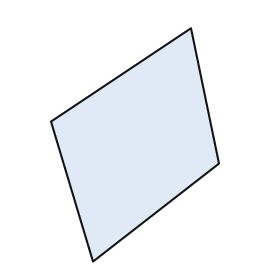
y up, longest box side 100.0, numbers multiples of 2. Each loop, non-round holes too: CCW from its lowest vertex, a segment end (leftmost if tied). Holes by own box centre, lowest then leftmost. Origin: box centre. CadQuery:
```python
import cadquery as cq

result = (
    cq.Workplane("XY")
    .moveTo(-18.0, -50.0)
    .lineTo(36.0, -8.0)
    .lineTo(24.0, 50.0)
    .lineTo(-36.0, 10.0)
    .close()
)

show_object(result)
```